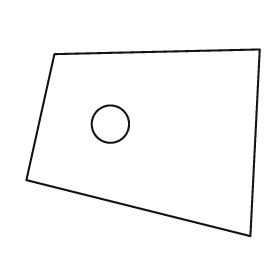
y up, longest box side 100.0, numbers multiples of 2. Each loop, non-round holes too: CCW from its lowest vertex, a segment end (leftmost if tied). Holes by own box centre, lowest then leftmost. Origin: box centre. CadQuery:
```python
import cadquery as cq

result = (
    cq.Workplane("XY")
    .moveTo(46.0, -40.0)
    .lineTo(50.0, 40.0)
    .lineTo(-38.0, 38.0)
    .lineTo(-50.0, -16.0)
    .close()
    .moveTo(-14.0, 8.0)
    .circle(8.0)
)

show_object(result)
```